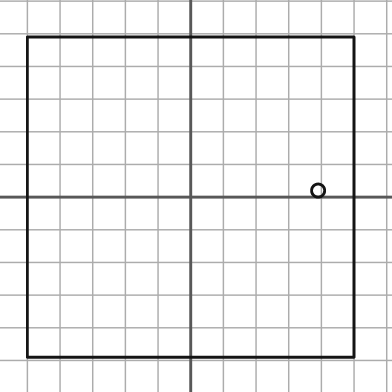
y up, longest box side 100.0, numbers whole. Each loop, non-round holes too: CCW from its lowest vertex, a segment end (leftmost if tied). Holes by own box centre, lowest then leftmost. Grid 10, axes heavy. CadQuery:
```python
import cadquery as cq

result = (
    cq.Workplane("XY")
    .moveTo(-50.0, -49.0)
    .lineTo(50.0, -49.0)
    .lineTo(50.0, 49.0)
    .lineTo(-50.0, 49.0)
    .close()
    .moveTo(39.0, 2.0)
    .circle(2.0)
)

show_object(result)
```